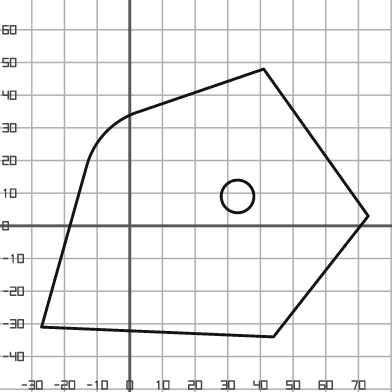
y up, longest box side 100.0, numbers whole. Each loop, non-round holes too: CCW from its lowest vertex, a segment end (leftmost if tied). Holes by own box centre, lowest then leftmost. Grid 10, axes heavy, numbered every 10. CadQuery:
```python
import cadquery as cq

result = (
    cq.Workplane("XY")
    .moveTo(44.0, -34.0)
    .lineTo(73.0, 3.0)
    .lineTo(41.0, 48.0)
    .lineTo(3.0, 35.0)
    .threePointArc((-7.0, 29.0), (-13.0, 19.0))
    .lineTo(-27.0, -31.0)
    .close()
    .moveTo(33.0, 9.0)
    .circle(5.0)
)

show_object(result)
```